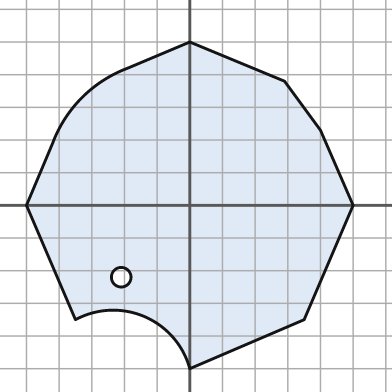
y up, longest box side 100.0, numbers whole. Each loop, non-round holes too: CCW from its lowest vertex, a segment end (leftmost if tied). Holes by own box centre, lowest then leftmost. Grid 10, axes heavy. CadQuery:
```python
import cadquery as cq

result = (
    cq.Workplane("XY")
    .moveTo(0.0, -50.0)
    .lineTo(35.0, -35.0)
    .lineTo(50.0, 0.0)
    .lineTo(40.0, 23.0)
    .lineTo(29.0, 38.0)
    .lineTo(0.0, 50.0)
    .lineTo(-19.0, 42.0)
    .threePointArc((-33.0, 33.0), (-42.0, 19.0))
    .lineTo(-50.0, 0.0)
    .lineTo(-35.0, -35.0)
    .threePointArc((-14.0, -34.0), (0.0, -50.0))
    .close()
    .moveTo(-21.0, -22.0)
    .circle(3.0)
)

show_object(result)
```